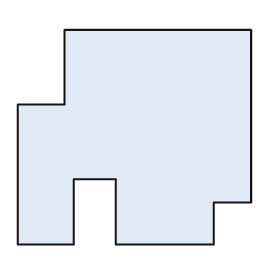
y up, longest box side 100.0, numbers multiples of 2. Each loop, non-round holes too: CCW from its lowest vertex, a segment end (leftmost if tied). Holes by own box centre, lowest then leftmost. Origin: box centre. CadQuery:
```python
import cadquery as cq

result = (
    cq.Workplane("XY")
    .moveTo(-50.0, -46.0)
    .lineTo(-26.0, -46.0)
    .lineTo(-26.0, -18.0)
    .lineTo(-8.0, -18.0)
    .lineTo(-8.0, -46.0)
    .lineTo(34.0, -46.0)
    .lineTo(34.0, -28.0)
    .lineTo(50.0, -28.0)
    .lineTo(50.0, 46.0)
    .lineTo(-30.0, 46.0)
    .lineTo(-30.0, 14.0)
    .lineTo(-50.0, 14.0)
    .close()
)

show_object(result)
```